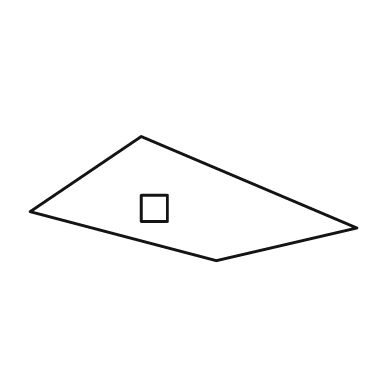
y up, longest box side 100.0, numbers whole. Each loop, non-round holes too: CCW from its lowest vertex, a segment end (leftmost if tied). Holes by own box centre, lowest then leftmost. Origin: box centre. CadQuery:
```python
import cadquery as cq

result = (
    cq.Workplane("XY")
    .moveTo(7.0, -19.0)
    .lineTo(50.0, -9.0)
    .lineTo(-16.0, 19.0)
    .lineTo(-50.0, -4.0)
    .close()
    .moveTo(-16.0, -7.0)
    .lineTo(-8.0, -7.0)
    .lineTo(-8.0, 1.0)
    .lineTo(-16.0, 1.0)
    .close()
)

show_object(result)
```